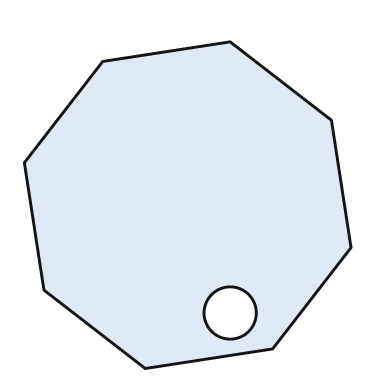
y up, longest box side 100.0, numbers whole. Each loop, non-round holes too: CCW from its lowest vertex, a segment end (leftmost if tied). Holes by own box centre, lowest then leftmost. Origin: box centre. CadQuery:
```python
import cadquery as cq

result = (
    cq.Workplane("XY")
    .moveTo(-13.0, -50.0)
    .lineTo(26.0, -44.0)
    .lineTo(50.0, -13.0)
    .lineTo(44.0, 26.0)
    .lineTo(13.0, 50.0)
    .lineTo(-26.0, 44.0)
    .lineTo(-50.0, 13.0)
    .lineTo(-44.0, -26.0)
    .close()
    .moveTo(13.0, -33.0)
    .circle(8.0)
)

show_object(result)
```